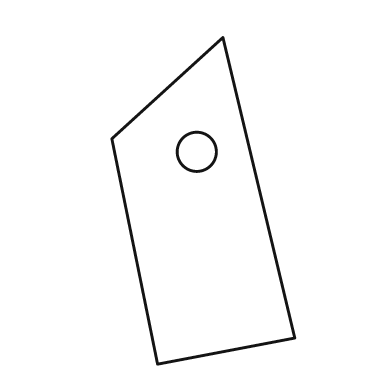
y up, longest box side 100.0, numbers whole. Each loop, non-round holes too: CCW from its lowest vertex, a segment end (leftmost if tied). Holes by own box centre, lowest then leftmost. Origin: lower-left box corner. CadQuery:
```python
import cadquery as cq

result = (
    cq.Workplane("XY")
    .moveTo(14.0, 0.0)
    .lineTo(56.0, 8.0)
    .lineTo(34.0, 100.0)
    .lineTo(0.0, 69.0)
    .close()
    .moveTo(26.0, 65.0)
    .circle(6.0)
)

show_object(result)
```